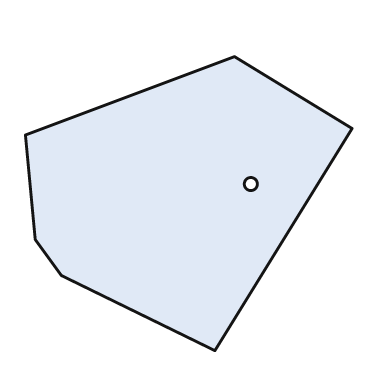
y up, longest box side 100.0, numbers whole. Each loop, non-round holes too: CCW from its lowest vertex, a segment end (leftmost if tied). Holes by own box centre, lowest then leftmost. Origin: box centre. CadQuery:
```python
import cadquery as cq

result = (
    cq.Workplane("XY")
    .moveTo(8.0, -45.0)
    .lineTo(50.0, 23.0)
    .lineTo(14.0, 45.0)
    .lineTo(-50.0, 21.0)
    .lineTo(-47.0, -11.0)
    .lineTo(-39.0, -22.0)
    .close()
    .moveTo(19.0, 6.0)
    .circle(2.0)
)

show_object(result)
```